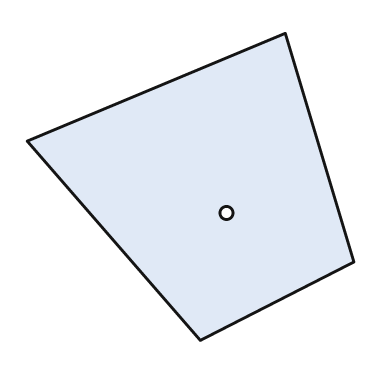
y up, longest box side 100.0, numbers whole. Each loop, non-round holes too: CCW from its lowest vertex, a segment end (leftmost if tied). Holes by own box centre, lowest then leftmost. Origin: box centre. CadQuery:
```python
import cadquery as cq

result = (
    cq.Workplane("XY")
    .moveTo(3.0, -47.0)
    .lineTo(50.0, -23.0)
    .lineTo(29.0, 47.0)
    .lineTo(-50.0, 14.0)
    .close()
    .moveTo(11.0, -8.0)
    .circle(2.0)
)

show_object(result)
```